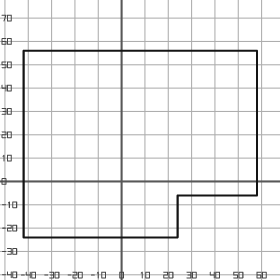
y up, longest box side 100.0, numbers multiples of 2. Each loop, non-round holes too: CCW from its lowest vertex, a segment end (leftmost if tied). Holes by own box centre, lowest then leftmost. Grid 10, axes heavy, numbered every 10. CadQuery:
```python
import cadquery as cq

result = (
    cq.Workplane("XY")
    .moveTo(-42.0, -24.0)
    .lineTo(24.0, -24.0)
    .lineTo(24.0, -6.0)
    .lineTo(58.0, -6.0)
    .lineTo(58.0, 56.0)
    .lineTo(-42.0, 56.0)
    .close()
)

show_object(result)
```